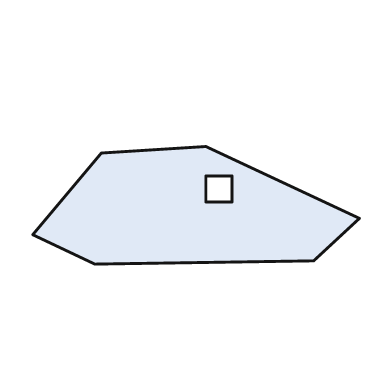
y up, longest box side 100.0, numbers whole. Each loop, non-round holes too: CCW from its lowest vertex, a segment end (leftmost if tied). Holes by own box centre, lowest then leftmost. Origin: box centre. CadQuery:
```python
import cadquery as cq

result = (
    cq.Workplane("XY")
    .moveTo(-31.0, -18.0)
    .lineTo(36.0, -17.0)
    .lineTo(50.0, -4.0)
    .lineTo(3.0, 18.0)
    .lineTo(-29.0, 16.0)
    .lineTo(-50.0, -9.0)
    .close()
    .moveTo(3.0, 1.0)
    .lineTo(11.0, 1.0)
    .lineTo(11.0, 9.0)
    .lineTo(3.0, 9.0)
    .close()
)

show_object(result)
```